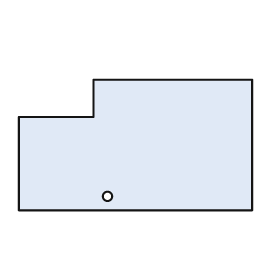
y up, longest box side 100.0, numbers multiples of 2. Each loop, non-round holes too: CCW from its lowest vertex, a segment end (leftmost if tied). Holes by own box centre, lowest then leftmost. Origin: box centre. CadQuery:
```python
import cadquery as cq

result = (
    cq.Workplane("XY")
    .moveTo(-50.0, -28.0)
    .lineTo(50.0, -28.0)
    .lineTo(50.0, 28.0)
    .lineTo(-18.0, 28.0)
    .lineTo(-18.0, 12.0)
    .lineTo(-50.0, 12.0)
    .close()
    .moveTo(-12.0, -22.0)
    .circle(2.0)
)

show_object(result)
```